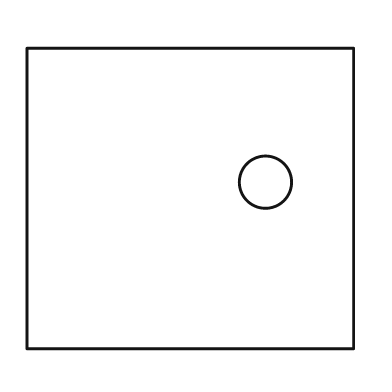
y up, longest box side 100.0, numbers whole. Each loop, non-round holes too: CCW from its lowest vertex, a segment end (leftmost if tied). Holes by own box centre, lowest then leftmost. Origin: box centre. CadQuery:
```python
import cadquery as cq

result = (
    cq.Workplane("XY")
    .moveTo(-50.0, -46.0)
    .lineTo(50.0, -46.0)
    .lineTo(50.0, 46.0)
    .lineTo(-50.0, 46.0)
    .close()
    .moveTo(23.0, 5.0)
    .circle(8.0)
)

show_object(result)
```